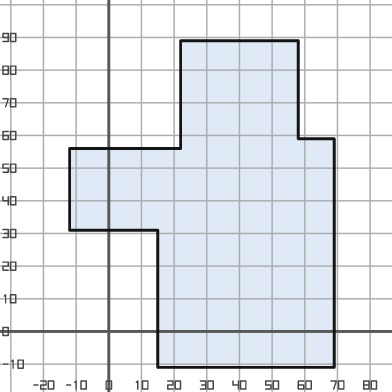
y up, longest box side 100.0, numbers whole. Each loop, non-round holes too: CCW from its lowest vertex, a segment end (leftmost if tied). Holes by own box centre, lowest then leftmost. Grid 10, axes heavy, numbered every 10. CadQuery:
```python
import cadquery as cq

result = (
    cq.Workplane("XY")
    .moveTo(15.0, -11.0)
    .lineTo(69.0, -11.0)
    .lineTo(69.0, 59.0)
    .lineTo(58.0, 59.0)
    .lineTo(58.0, 89.0)
    .lineTo(22.0, 89.0)
    .lineTo(22.0, 56.0)
    .lineTo(-12.0, 56.0)
    .lineTo(-12.0, 31.0)
    .lineTo(15.0, 31.0)
    .close()
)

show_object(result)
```